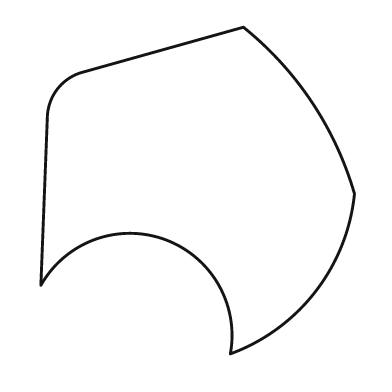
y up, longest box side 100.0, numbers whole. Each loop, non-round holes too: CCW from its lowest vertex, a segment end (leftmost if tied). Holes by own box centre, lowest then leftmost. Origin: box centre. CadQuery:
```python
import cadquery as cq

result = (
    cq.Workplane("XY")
    .moveTo(10.0, -50.0)
    .threePointArc((36.0, -31.0), (48.0, -1.0))
    .threePointArc((35.0, 27.0), (14.0, 50.0))
    .lineTo(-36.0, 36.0)
    .threePointArc((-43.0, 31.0), (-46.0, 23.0))
    .lineTo(-48.0, -29.0)
    .threePointArc((-10.0, -15.0), (10.0, -50.0))
    .close()
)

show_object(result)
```